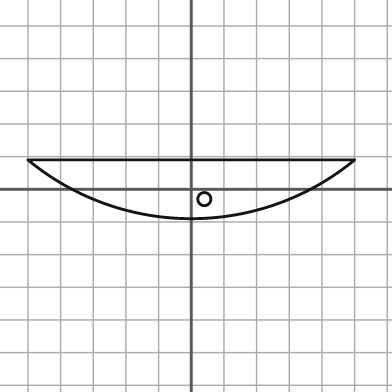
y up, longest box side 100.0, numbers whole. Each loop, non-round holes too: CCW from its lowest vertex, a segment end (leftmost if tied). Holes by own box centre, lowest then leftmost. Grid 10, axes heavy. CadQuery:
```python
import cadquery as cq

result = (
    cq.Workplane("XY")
    .moveTo(-50.0, 9.0)
    .threePointArc((0.0, -9.0), (50.0, 9.0))
    .close()
    .moveTo(4.0, -3.0)
    .circle(2.0)
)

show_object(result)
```